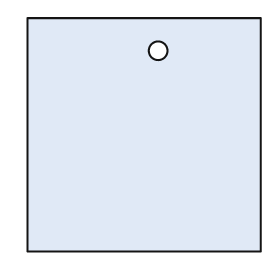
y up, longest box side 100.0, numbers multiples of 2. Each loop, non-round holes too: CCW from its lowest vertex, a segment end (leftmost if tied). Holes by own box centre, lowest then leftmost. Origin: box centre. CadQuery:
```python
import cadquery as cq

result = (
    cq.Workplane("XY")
    .moveTo(-50.0, -50.0)
    .lineTo(50.0, -50.0)
    .lineTo(50.0, 50.0)
    .lineTo(-50.0, 50.0)
    .close()
    .moveTo(6.0, 36.0)
    .circle(4.0)
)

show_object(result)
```